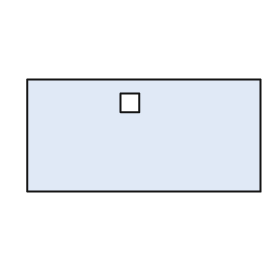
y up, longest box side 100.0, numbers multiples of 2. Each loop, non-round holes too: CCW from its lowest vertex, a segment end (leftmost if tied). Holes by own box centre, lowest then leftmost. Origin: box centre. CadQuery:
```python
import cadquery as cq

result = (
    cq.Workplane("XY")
    .moveTo(-50.0, -24.0)
    .lineTo(50.0, -24.0)
    .lineTo(50.0, 24.0)
    .lineTo(-50.0, 24.0)
    .close()
    .moveTo(-10.0, 10.0)
    .lineTo(-2.0, 10.0)
    .lineTo(-2.0, 18.0)
    .lineTo(-10.0, 18.0)
    .close()
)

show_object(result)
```